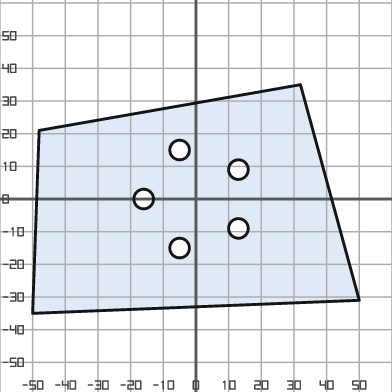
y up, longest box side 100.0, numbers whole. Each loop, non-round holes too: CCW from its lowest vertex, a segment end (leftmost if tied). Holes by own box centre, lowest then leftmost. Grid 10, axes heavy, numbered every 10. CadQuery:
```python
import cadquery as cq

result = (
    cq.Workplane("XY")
    .moveTo(-50.0, -35.0)
    .lineTo(50.0, -31.0)
    .lineTo(32.0, 35.0)
    .lineTo(-48.0, 21.0)
    .close()
    .moveTo(-5.0, -15.0)
    .circle(3.0)
    .moveTo(13.0, -9.0)
    .circle(3.0)
    .moveTo(-16.0, 0.0)
    .circle(3.0)
    .moveTo(13.0, 9.0)
    .circle(3.0)
    .moveTo(-5.0, 15.0)
    .circle(3.0)
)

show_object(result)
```